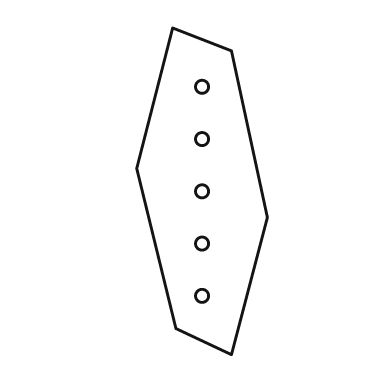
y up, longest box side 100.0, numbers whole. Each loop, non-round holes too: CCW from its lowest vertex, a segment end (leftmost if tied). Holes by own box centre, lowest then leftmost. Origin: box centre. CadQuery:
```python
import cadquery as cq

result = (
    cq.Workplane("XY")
    .moveTo(9.0, -50.0)
    .lineTo(20.0, -8.0)
    .lineTo(9.0, 43.0)
    .lineTo(-9.0, 50.0)
    .lineTo(-20.0, 7.0)
    .lineTo(-8.0, -42.0)
    .close()
    .moveTo(0.0, -32.0)
    .circle(2.0)
    .moveTo(0.0, -16.0)
    .circle(2.0)
    .moveTo(0.0, 0.0)
    .circle(2.0)
    .moveTo(0.0, 16.0)
    .circle(2.0)
    .moveTo(0.0, 32.0)
    .circle(2.0)
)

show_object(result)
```